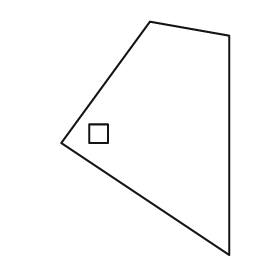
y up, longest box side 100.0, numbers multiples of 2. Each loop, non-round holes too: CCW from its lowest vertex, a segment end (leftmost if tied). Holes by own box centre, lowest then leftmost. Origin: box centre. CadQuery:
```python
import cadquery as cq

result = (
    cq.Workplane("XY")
    .moveTo(36.0, -50.0)
    .lineTo(36.0, 44.0)
    .lineTo(2.0, 50.0)
    .lineTo(-36.0, -2.0)
    .close()
    .moveTo(-24.0, -2.0)
    .lineTo(-16.0, -2.0)
    .lineTo(-16.0, 6.0)
    .lineTo(-24.0, 6.0)
    .close()
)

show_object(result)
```